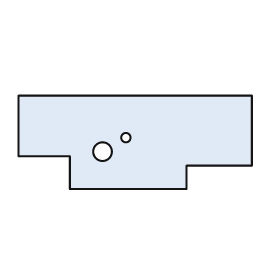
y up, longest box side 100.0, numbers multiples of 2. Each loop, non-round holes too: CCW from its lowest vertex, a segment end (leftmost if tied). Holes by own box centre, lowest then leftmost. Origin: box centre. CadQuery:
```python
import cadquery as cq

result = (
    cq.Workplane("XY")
    .moveTo(-28.0, -20.0)
    .lineTo(22.0, -20.0)
    .lineTo(22.0, -10.0)
    .lineTo(50.0, -10.0)
    .lineTo(50.0, 20.0)
    .lineTo(-50.0, 20.0)
    .lineTo(-50.0, -6.0)
    .lineTo(-28.0, -6.0)
    .close()
    .moveTo(-14.0, -4.0)
    .circle(4.0)
    .moveTo(-4.0, 2.0)
    .circle(2.0)
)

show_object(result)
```